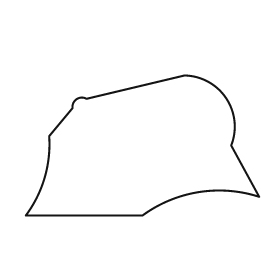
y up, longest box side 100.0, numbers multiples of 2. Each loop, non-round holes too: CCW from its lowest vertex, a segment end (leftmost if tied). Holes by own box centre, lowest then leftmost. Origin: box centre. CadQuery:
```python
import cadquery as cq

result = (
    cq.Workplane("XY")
    .moveTo(-50.0, -30.0)
    .lineTo(0.0, -30.0)
    .threePointArc((24.0, -20.0), (50.0, -22.0))
    .lineTo(38.0, 0.0)
    .threePointArc((36.0, 20.0), (18.0, 30.0))
    .lineTo(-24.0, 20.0)
    .threePointArc((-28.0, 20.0), (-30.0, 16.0))
    .lineTo(-40.0, 4.0)
    .threePointArc((-42.0, -14.0), (-50.0, -30.0))
    .close()
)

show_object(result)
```